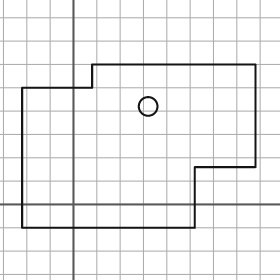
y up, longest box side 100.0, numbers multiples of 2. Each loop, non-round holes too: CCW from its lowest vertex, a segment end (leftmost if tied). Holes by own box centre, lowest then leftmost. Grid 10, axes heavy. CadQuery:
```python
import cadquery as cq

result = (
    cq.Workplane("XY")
    .moveTo(-22.0, -10.0)
    .lineTo(52.0, -10.0)
    .lineTo(52.0, 16.0)
    .lineTo(78.0, 16.0)
    .lineTo(78.0, 60.0)
    .lineTo(8.0, 60.0)
    .lineTo(8.0, 50.0)
    .lineTo(-22.0, 50.0)
    .close()
    .moveTo(32.0, 42.0)
    .circle(4.0)
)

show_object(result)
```